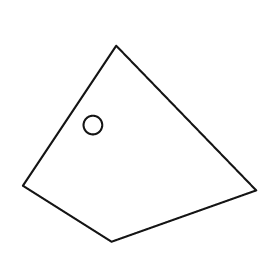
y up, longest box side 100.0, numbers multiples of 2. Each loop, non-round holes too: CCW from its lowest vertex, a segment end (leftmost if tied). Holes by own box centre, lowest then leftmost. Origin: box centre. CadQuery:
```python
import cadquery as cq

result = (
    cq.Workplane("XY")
    .moveTo(-12.0, -42.0)
    .lineTo(50.0, -20.0)
    .lineTo(-10.0, 42.0)
    .lineTo(-50.0, -18.0)
    .close()
    .moveTo(-20.0, 8.0)
    .circle(4.0)
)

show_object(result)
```